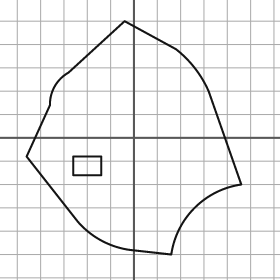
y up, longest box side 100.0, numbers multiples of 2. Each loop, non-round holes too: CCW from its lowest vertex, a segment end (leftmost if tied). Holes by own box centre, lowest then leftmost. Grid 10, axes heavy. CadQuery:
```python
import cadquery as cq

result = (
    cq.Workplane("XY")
    .moveTo(16.0, -50.0)
    .threePointArc((26.0, -30.0), (46.0, -20.0))
    .lineTo(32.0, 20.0)
    .threePointArc((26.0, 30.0), (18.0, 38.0))
    .lineTo(-4.0, 50.0)
    .lineTo(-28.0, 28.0)
    .threePointArc((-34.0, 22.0), (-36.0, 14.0))
    .lineTo(-46.0, -8.0)
    .lineTo(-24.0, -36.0)
    .threePointArc((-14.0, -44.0), (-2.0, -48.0))
    .close()
    .moveTo(-26.0, -16.0)
    .lineTo(-14.0, -16.0)
    .lineTo(-14.0, -8.0)
    .lineTo(-26.0, -8.0)
    .close()
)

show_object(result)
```